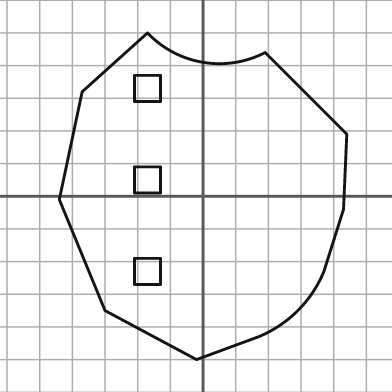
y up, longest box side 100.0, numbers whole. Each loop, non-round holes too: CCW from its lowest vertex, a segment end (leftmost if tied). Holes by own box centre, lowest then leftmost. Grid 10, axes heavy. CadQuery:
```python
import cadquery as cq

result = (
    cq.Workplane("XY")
    .moveTo(-2.0, -50.0)
    .lineTo(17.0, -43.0)
    .threePointArc((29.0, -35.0), (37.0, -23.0))
    .lineTo(43.0, -4.0)
    .lineTo(44.0, 19.0)
    .lineTo(19.0, 44.0)
    .threePointArc((0.0, 41.0), (-17.0, 50.0))
    .lineTo(-37.0, 32.0)
    .lineTo(-44.0, -1.0)
    .lineTo(-30.0, -35.0)
    .close()
    .moveTo(-21.0, -27.0)
    .lineTo(-13.0, -27.0)
    .lineTo(-13.0, -19.0)
    .lineTo(-21.0, -19.0)
    .close()
    .moveTo(-21.0, 1.0)
    .lineTo(-13.0, 1.0)
    .lineTo(-13.0, 9.0)
    .lineTo(-21.0, 9.0)
    .close()
    .moveTo(-21.0, 29.0)
    .lineTo(-13.0, 29.0)
    .lineTo(-13.0, 37.0)
    .lineTo(-21.0, 37.0)
    .close()
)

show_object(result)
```